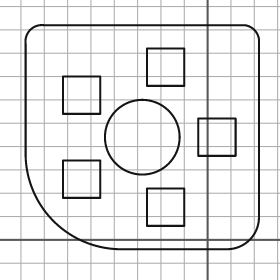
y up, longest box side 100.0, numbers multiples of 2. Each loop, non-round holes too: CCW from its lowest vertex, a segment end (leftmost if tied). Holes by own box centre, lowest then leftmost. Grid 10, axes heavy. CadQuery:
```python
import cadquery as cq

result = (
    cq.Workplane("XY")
    .moveTo(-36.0, -4.0)
    .lineTo(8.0, -4.0)
    .threePointArc((18.0, 0.0), (22.0, 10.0))
    .lineTo(22.0, 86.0)
    .threePointArc((20.0, 90.0), (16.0, 92.0))
    .lineTo(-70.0, 92.0)
    .threePointArc((-76.0, 90.0), (-78.0, 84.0))
    .lineTo(-78.0, 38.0)
    .threePointArc((-66.0, 8.0), (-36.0, -4.0))
    .close()
    .moveTo(-26.0, 6.0)
    .lineTo(-10.0, 6.0)
    .lineTo(-10.0, 22.0)
    .lineTo(-26.0, 22.0)
    .close()
    .moveTo(-62.0, 18.0)
    .lineTo(-46.0, 18.0)
    .lineTo(-46.0, 34.0)
    .lineTo(-62.0, 34.0)
    .close()
    .moveTo(-28.0, 44.0)
    .circle(16.0)
    .moveTo(-4.0, 36.0)
    .lineTo(12.0, 36.0)
    .lineTo(12.0, 52.0)
    .lineTo(-4.0, 52.0)
    .close()
    .moveTo(-62.0, 54.0)
    .lineTo(-46.0, 54.0)
    .lineTo(-46.0, 70.0)
    .lineTo(-62.0, 70.0)
    .close()
    .moveTo(-26.0, 66.0)
    .lineTo(-10.0, 66.0)
    .lineTo(-10.0, 82.0)
    .lineTo(-26.0, 82.0)
    .close()
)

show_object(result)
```